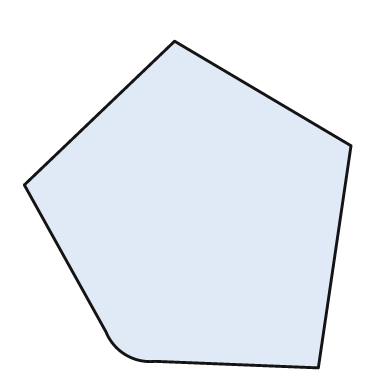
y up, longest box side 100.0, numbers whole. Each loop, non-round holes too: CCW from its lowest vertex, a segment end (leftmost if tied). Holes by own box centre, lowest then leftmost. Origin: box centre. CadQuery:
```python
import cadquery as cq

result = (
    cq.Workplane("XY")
    .moveTo(40.0, -50.0)
    .lineTo(50.0, 18.0)
    .lineTo(-4.0, 50.0)
    .lineTo(-50.0, 6.0)
    .lineTo(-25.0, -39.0)
    .threePointArc((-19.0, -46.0), (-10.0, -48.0))
    .close()
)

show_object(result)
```